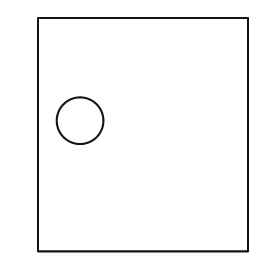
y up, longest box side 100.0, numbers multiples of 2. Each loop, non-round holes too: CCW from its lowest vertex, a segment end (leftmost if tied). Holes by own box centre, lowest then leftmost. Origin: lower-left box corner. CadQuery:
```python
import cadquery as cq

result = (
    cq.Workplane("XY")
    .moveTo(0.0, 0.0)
    .lineTo(90.0, 0.0)
    .lineTo(90.0, 100.0)
    .lineTo(0.0, 100.0)
    .close()
    .moveTo(18.0, 56.0)
    .circle(10.0)
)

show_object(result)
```